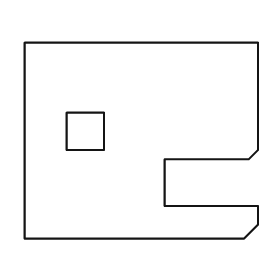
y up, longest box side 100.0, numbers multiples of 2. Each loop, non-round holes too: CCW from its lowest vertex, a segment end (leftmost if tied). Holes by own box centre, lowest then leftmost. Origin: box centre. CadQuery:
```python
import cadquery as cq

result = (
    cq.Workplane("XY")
    .moveTo(-50.0, -42.0)
    .lineTo(44.0, -42.0)
    .lineTo(50.0, -36.0)
    .lineTo(50.0, -28.0)
    .lineTo(10.0, -28.0)
    .lineTo(10.0, -8.0)
    .lineTo(46.0, -8.0)
    .lineTo(50.0, -4.0)
    .lineTo(50.0, 42.0)
    .lineTo(-50.0, 42.0)
    .close()
    .moveTo(-32.0, -4.0)
    .lineTo(-16.0, -4.0)
    .lineTo(-16.0, 12.0)
    .lineTo(-32.0, 12.0)
    .close()
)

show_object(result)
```